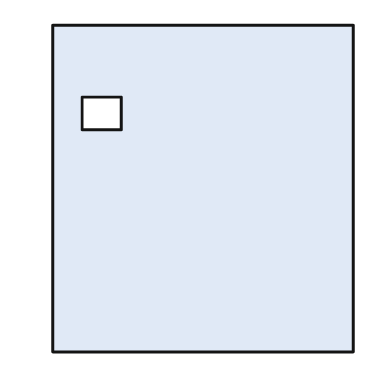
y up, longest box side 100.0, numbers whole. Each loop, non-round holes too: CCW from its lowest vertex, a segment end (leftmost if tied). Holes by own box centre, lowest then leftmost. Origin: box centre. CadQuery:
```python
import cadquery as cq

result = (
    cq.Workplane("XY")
    .moveTo(-46.0, -50.0)
    .lineTo(46.0, -50.0)
    .lineTo(46.0, 50.0)
    .lineTo(-46.0, 50.0)
    .close()
    .moveTo(-37.0, 18.0)
    .lineTo(-25.0, 18.0)
    .lineTo(-25.0, 28.0)
    .lineTo(-37.0, 28.0)
    .close()
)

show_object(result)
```